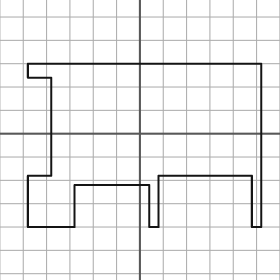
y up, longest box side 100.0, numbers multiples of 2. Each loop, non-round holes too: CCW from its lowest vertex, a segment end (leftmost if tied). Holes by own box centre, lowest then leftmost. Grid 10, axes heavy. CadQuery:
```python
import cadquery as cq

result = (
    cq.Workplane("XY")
    .moveTo(-48.0, -40.0)
    .lineTo(-28.0, -40.0)
    .lineTo(-28.0, -22.0)
    .lineTo(4.0, -22.0)
    .lineTo(4.0, -40.0)
    .lineTo(8.0, -40.0)
    .lineTo(8.0, -18.0)
    .lineTo(48.0, -18.0)
    .lineTo(48.0, -40.0)
    .lineTo(52.0, -40.0)
    .lineTo(52.0, 30.0)
    .lineTo(-48.0, 30.0)
    .lineTo(-48.0, 24.0)
    .lineTo(-38.0, 24.0)
    .lineTo(-38.0, -18.0)
    .lineTo(-48.0, -18.0)
    .close()
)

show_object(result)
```